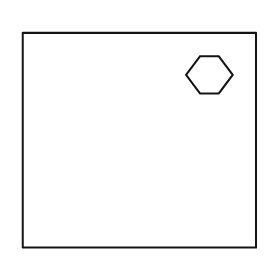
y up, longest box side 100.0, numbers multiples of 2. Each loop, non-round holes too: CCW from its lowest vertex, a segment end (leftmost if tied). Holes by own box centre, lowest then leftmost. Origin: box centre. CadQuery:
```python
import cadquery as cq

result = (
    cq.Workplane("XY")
    .moveTo(-50.0, -46.0)
    .lineTo(50.0, -46.0)
    .lineTo(50.0, 46.0)
    .lineTo(-50.0, 46.0)
    .close()
    .moveTo(26.0, 20.0)
    .lineTo(34.0, 20.0)
    .lineTo(40.0, 28.0)
    .lineTo(34.0, 36.0)
    .lineTo(26.0, 36.0)
    .lineTo(20.0, 28.0)
    .close()
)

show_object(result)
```